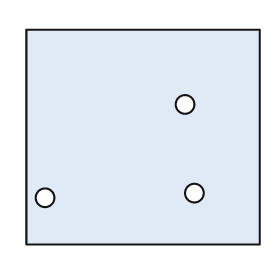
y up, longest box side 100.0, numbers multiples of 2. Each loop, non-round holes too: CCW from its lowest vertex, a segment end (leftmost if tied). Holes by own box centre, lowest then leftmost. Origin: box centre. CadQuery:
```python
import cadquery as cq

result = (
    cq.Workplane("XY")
    .moveTo(-50.0, -46.0)
    .lineTo(50.0, -46.0)
    .lineTo(50.0, 46.0)
    .lineTo(-50.0, 46.0)
    .close()
    .moveTo(-42.0, -26.0)
    .circle(4.0)
    .moveTo(22.0, -24.0)
    .circle(4.0)
    .moveTo(18.0, 14.0)
    .circle(4.0)
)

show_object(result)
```